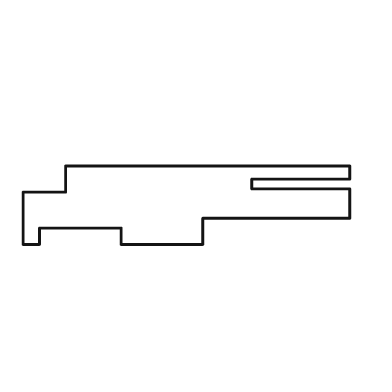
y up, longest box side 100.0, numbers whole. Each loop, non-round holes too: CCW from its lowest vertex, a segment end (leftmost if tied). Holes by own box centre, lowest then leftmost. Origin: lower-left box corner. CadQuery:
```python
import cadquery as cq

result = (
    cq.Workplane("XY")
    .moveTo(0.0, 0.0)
    .lineTo(5.0, 0.0)
    .lineTo(5.0, 5.0)
    .lineTo(30.0, 5.0)
    .lineTo(30.0, 0.0)
    .lineTo(55.0, 0.0)
    .lineTo(55.0, 8.0)
    .lineTo(100.0, 8.0)
    .lineTo(100.0, 17.0)
    .lineTo(70.0, 17.0)
    .lineTo(70.0, 20.0)
    .lineTo(100.0, 20.0)
    .lineTo(100.0, 24.0)
    .lineTo(13.0, 24.0)
    .lineTo(13.0, 16.0)
    .lineTo(0.0, 16.0)
    .close()
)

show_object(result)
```